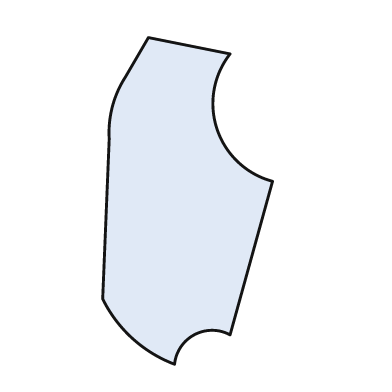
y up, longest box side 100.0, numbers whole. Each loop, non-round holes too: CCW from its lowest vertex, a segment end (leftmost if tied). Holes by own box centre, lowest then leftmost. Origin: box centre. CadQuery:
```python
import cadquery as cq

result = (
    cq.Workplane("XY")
    .moveTo(-4.0, -50.0)
    .threePointArc((2.0, -41.0), (13.0, -41.0))
    .lineTo(26.0, 6.0)
    .threePointArc((9.0, 22.0), (13.0, 45.0))
    .lineTo(-12.0, 50.0)
    .lineTo(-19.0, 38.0)
    .threePointArc((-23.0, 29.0), (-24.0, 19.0))
    .lineTo(-26.0, -30.0)
    .threePointArc((-17.0, -42.0), (-4.0, -50.0))
    .close()
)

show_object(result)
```